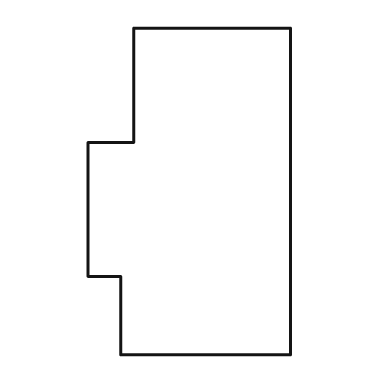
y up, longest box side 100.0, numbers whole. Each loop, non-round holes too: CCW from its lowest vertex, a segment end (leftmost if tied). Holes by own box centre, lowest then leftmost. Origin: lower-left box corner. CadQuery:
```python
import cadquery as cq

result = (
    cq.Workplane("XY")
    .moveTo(10.0, 0.0)
    .lineTo(62.0, 0.0)
    .lineTo(62.0, 100.0)
    .lineTo(14.0, 100.0)
    .lineTo(14.0, 65.0)
    .lineTo(0.0, 65.0)
    .lineTo(0.0, 24.0)
    .lineTo(10.0, 24.0)
    .close()
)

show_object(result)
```